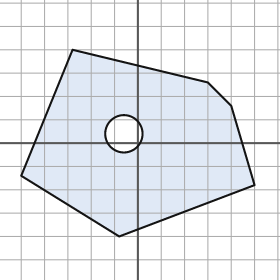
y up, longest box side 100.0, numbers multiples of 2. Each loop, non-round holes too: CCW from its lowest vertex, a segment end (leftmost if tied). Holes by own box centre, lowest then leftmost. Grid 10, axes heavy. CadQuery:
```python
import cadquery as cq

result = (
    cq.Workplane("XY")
    .moveTo(-8.0, -40.0)
    .lineTo(50.0, -18.0)
    .lineTo(40.0, 16.0)
    .lineTo(30.0, 26.0)
    .lineTo(-28.0, 40.0)
    .lineTo(-50.0, -14.0)
    .close()
    .moveTo(-6.0, 4.0)
    .circle(8.0)
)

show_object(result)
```